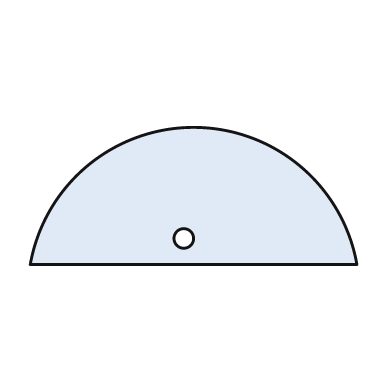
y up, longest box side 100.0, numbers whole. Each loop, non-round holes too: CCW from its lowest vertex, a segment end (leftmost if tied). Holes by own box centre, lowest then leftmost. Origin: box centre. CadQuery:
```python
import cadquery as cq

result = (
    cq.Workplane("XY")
    .moveTo(-50.0, -21.0)
    .lineTo(50.0, -21.0)
    .threePointArc((0.0, 21.0), (-50.0, -21.0))
    .close()
    .moveTo(-3.0, -13.0)
    .circle(3.0)
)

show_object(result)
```